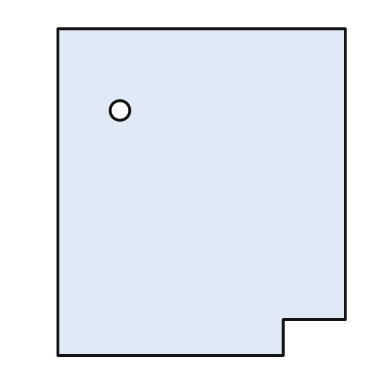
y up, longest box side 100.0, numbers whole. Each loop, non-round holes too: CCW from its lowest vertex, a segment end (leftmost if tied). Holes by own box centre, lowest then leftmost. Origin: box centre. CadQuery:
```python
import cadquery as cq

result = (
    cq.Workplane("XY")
    .moveTo(-44.0, -50.0)
    .lineTo(25.0, -50.0)
    .lineTo(25.0, -39.0)
    .lineTo(44.0, -39.0)
    .lineTo(44.0, 50.0)
    .lineTo(-44.0, 50.0)
    .close()
    .moveTo(-25.0, 25.0)
    .circle(3.0)
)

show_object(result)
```